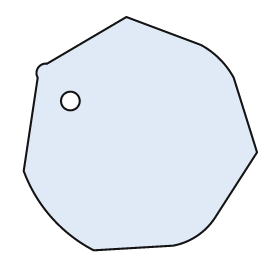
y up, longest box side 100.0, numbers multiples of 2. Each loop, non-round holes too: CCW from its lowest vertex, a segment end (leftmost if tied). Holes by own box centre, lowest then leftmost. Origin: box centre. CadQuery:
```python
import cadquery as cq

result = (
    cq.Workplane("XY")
    .moveTo(-20.0, -50.0)
    .lineTo(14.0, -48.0)
    .threePointArc((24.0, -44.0), (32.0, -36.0))
    .lineTo(50.0, -8.0)
    .lineTo(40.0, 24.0)
    .threePointArc((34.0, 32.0), (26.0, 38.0))
    .lineTo(-6.0, 50.0)
    .lineTo(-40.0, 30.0)
    .threePointArc((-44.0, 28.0), (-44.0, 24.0))
    .lineTo(-50.0, -16.0)
    .threePointArc((-38.0, -36.0), (-20.0, -50.0))
    .close()
    .moveTo(-30.0, 14.0)
    .circle(4.0)
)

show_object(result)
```